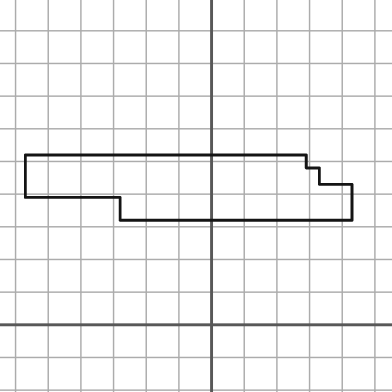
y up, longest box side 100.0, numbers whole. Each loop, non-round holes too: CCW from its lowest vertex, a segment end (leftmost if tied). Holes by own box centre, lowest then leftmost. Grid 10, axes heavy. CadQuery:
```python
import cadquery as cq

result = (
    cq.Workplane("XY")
    .moveTo(-28.0, 32.0)
    .lineTo(43.0, 32.0)
    .lineTo(43.0, 43.0)
    .lineTo(33.0, 43.0)
    .lineTo(33.0, 48.0)
    .lineTo(29.0, 48.0)
    .lineTo(29.0, 52.0)
    .lineTo(-57.0, 52.0)
    .lineTo(-57.0, 39.0)
    .lineTo(-28.0, 39.0)
    .close()
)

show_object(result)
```